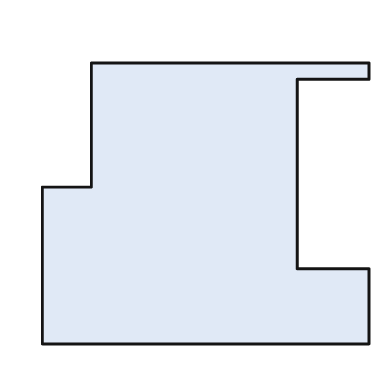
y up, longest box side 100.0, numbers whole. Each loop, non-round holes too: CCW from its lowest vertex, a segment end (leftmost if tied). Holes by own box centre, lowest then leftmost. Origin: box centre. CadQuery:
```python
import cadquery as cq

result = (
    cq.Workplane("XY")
    .moveTo(-50.0, -43.0)
    .lineTo(50.0, -43.0)
    .lineTo(50.0, -20.0)
    .lineTo(28.0, -20.0)
    .lineTo(28.0, 38.0)
    .lineTo(50.0, 38.0)
    .lineTo(50.0, 43.0)
    .lineTo(-35.0, 43.0)
    .lineTo(-35.0, 5.0)
    .lineTo(-50.0, 5.0)
    .close()
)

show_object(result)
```